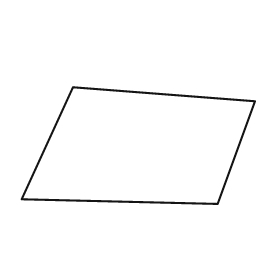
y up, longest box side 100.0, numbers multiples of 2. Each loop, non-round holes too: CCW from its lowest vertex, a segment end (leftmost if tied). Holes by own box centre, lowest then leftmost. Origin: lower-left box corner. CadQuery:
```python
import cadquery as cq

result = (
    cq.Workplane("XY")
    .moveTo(84.0, 0.0)
    .lineTo(100.0, 44.0)
    .lineTo(22.0, 50.0)
    .lineTo(0.0, 2.0)
    .close()
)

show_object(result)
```